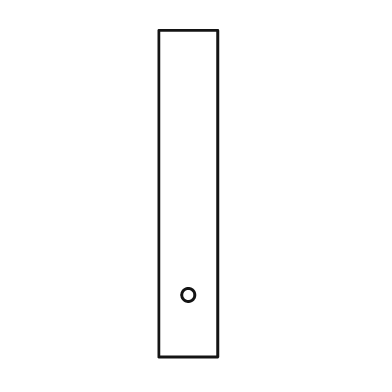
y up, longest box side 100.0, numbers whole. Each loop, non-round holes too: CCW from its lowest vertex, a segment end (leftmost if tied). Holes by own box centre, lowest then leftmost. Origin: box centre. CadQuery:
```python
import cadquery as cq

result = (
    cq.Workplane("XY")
    .moveTo(-9.0, -50.0)
    .lineTo(9.0, -50.0)
    .lineTo(9.0, 50.0)
    .lineTo(-9.0, 50.0)
    .close()
    .moveTo(0.0, -31.0)
    .circle(2.0)
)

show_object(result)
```